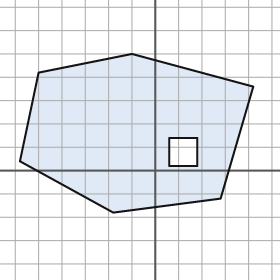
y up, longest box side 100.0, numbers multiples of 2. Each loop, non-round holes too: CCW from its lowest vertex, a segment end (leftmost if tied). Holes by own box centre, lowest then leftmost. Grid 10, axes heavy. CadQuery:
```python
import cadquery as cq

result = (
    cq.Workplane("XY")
    .moveTo(-18.0, -18.0)
    .lineTo(28.0, -12.0)
    .lineTo(42.0, 36.0)
    .lineTo(-10.0, 50.0)
    .lineTo(-50.0, 42.0)
    .lineTo(-58.0, 4.0)
    .close()
    .moveTo(6.0, 2.0)
    .lineTo(18.0, 2.0)
    .lineTo(18.0, 14.0)
    .lineTo(6.0, 14.0)
    .close()
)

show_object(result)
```